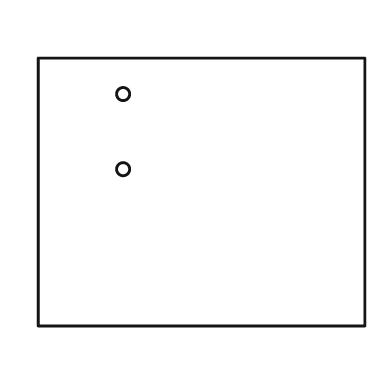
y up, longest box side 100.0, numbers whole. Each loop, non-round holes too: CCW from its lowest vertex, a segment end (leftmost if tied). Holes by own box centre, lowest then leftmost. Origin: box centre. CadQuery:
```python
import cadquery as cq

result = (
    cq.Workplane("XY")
    .moveTo(-50.0, -41.0)
    .lineTo(50.0, -41.0)
    .lineTo(50.0, 41.0)
    .lineTo(-50.0, 41.0)
    .close()
    .moveTo(-24.0, 7.0)
    .circle(2.0)
    .moveTo(-24.0, 30.0)
    .circle(2.0)
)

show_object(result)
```